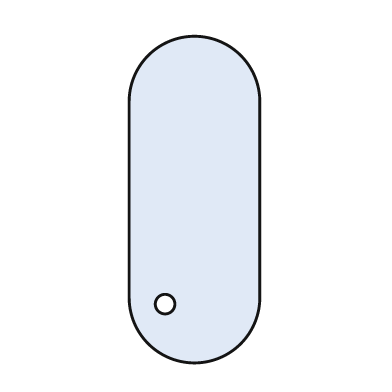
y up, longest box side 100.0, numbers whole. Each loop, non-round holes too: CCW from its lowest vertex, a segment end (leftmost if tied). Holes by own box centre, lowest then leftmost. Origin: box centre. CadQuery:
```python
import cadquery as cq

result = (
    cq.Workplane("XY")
    .moveTo(-20.0, -30.0)
    .threePointArc((0.0, -50.0), (20.0, -30.0))
    .lineTo(20.0, 30.0)
    .threePointArc((0.0, 50.0), (-20.0, 30.0))
    .close()
    .moveTo(-9.0, -32.0)
    .circle(3.0)
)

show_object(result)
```